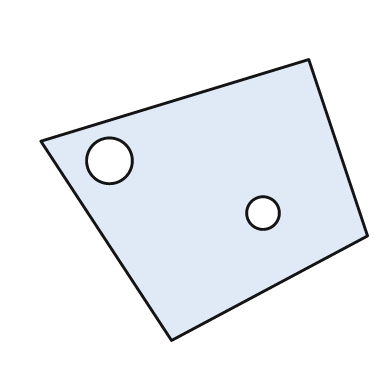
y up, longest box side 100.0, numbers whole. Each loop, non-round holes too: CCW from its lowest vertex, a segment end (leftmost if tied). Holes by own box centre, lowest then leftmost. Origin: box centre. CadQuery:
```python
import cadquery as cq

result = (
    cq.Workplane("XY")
    .moveTo(-10.0, -43.0)
    .lineTo(50.0, -11.0)
    .lineTo(32.0, 43.0)
    .lineTo(-50.0, 18.0)
    .close()
    .moveTo(18.0, -4.0)
    .circle(5.0)
    .moveTo(-29.0, 12.0)
    .circle(7.0)
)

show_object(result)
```